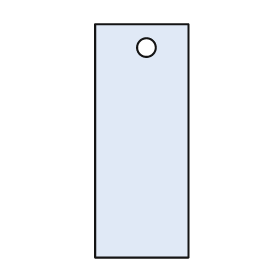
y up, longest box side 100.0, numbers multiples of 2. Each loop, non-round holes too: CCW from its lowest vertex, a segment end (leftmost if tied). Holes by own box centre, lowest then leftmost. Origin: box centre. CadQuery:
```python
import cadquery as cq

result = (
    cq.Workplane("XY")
    .moveTo(-20.0, -50.0)
    .lineTo(20.0, -50.0)
    .lineTo(20.0, 50.0)
    .lineTo(-20.0, 50.0)
    .close()
    .moveTo(2.0, 40.0)
    .circle(4.0)
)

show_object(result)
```